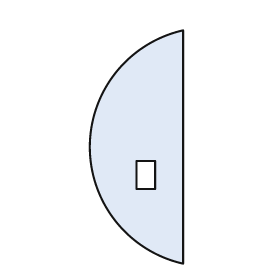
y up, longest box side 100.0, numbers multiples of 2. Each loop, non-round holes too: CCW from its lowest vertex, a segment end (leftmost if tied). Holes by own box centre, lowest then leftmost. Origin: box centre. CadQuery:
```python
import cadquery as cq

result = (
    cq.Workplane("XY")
    .moveTo(20.0, -50.0)
    .lineTo(20.0, 50.0)
    .threePointArc((-20.0, 0.0), (20.0, -50.0))
    .close()
    .moveTo(0.0, -18.0)
    .lineTo(8.0, -18.0)
    .lineTo(8.0, -6.0)
    .lineTo(0.0, -6.0)
    .close()
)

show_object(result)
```